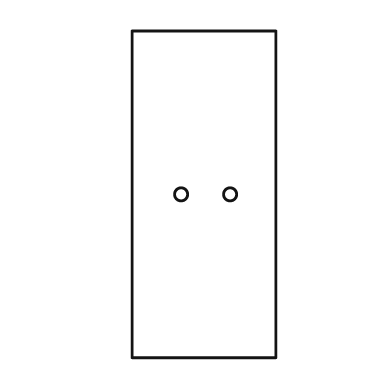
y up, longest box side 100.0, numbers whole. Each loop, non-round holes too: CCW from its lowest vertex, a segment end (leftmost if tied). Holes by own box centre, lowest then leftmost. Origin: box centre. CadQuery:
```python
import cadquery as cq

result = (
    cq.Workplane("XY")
    .moveTo(-22.0, -50.0)
    .lineTo(22.0, -50.0)
    .lineTo(22.0, 50.0)
    .lineTo(-22.0, 50.0)
    .close()
    .moveTo(-7.0, 0.0)
    .circle(2.0)
    .moveTo(8.0, 0.0)
    .circle(2.0)
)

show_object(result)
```